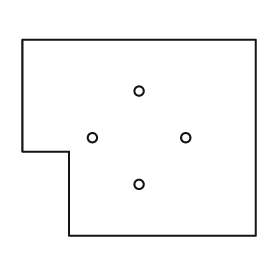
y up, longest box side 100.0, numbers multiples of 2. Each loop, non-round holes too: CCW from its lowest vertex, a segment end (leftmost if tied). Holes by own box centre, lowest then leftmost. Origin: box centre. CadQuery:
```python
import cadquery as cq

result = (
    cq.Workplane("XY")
    .moveTo(-30.0, -42.0)
    .lineTo(50.0, -42.0)
    .lineTo(50.0, 42.0)
    .lineTo(-50.0, 42.0)
    .lineTo(-50.0, -6.0)
    .lineTo(-30.0, -6.0)
    .close()
    .moveTo(0.0, -20.0)
    .circle(2.0)
    .moveTo(-20.0, 0.0)
    .circle(2.0)
    .moveTo(20.0, 0.0)
    .circle(2.0)
    .moveTo(0.0, 20.0)
    .circle(2.0)
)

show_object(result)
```